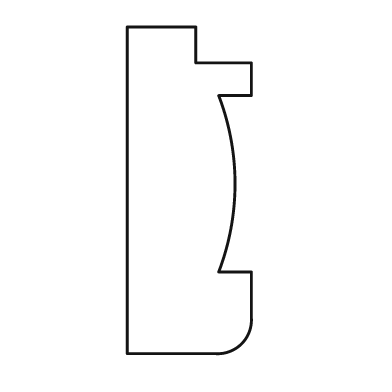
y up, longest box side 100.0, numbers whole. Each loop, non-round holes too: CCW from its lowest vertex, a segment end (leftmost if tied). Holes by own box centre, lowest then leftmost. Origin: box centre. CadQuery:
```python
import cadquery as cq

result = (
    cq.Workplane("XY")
    .moveTo(-19.0, -50.0)
    .lineTo(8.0, -50.0)
    .threePointArc((16.0, -47.0), (19.0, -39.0))
    .lineTo(19.0, -25.0)
    .lineTo(9.0, -25.0)
    .threePointArc((14.0, 2.0), (9.0, 29.0))
    .lineTo(19.0, 29.0)
    .lineTo(19.0, 39.0)
    .lineTo(2.0, 39.0)
    .lineTo(2.0, 50.0)
    .lineTo(-19.0, 50.0)
    .close()
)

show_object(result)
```